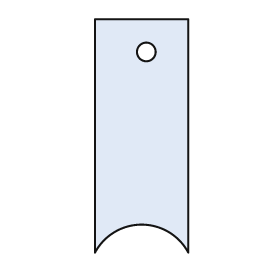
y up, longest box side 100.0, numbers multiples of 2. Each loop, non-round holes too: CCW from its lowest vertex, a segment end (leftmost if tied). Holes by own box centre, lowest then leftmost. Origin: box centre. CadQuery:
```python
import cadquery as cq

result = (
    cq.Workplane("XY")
    .moveTo(-20.0, -50.0)
    .threePointArc((0.0, -38.0), (20.0, -50.0))
    .lineTo(20.0, 50.0)
    .lineTo(-20.0, 50.0)
    .close()
    .moveTo(2.0, 36.0)
    .circle(4.0)
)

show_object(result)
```